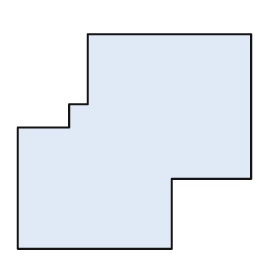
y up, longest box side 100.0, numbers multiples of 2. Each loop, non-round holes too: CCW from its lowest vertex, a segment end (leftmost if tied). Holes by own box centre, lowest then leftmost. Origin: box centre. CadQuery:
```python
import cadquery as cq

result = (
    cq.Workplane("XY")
    .moveTo(-50.0, -46.0)
    .lineTo(16.0, -46.0)
    .lineTo(16.0, -16.0)
    .lineTo(50.0, -16.0)
    .lineTo(50.0, 46.0)
    .lineTo(-20.0, 46.0)
    .lineTo(-20.0, 16.0)
    .lineTo(-28.0, 16.0)
    .lineTo(-28.0, 6.0)
    .lineTo(-50.0, 6.0)
    .close()
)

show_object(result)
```